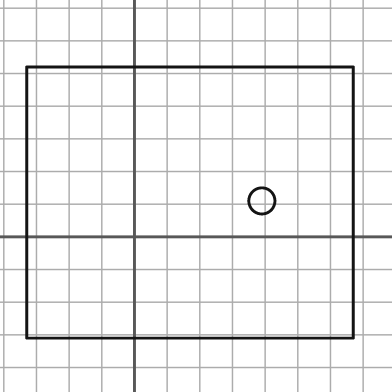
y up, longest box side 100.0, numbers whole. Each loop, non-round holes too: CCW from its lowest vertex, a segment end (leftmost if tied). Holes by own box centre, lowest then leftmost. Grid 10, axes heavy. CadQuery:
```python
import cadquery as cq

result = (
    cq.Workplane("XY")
    .moveTo(-33.0, -31.0)
    .lineTo(67.0, -31.0)
    .lineTo(67.0, 52.0)
    .lineTo(-33.0, 52.0)
    .close()
    .moveTo(39.0, 11.0)
    .circle(4.0)
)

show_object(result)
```